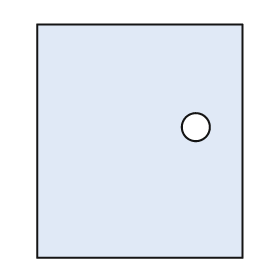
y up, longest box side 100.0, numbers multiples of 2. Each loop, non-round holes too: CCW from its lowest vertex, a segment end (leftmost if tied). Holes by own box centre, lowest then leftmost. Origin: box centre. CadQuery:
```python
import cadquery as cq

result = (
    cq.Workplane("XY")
    .moveTo(-44.0, -50.0)
    .lineTo(44.0, -50.0)
    .lineTo(44.0, 50.0)
    .lineTo(-44.0, 50.0)
    .close()
    .moveTo(24.0, 6.0)
    .circle(6.0)
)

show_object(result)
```